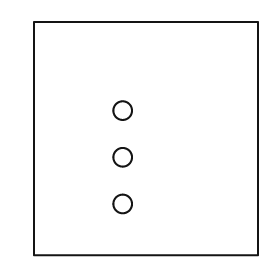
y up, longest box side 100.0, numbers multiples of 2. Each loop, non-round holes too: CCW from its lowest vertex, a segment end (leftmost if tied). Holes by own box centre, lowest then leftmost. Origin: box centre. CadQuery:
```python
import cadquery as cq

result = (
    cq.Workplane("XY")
    .moveTo(-48.0, -50.0)
    .lineTo(48.0, -50.0)
    .lineTo(48.0, 50.0)
    .lineTo(-48.0, 50.0)
    .close()
    .moveTo(-10.0, -28.0)
    .circle(4.0)
    .moveTo(-10.0, -8.0)
    .circle(4.0)
    .moveTo(-10.0, 12.0)
    .circle(4.0)
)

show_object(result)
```